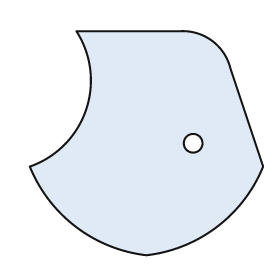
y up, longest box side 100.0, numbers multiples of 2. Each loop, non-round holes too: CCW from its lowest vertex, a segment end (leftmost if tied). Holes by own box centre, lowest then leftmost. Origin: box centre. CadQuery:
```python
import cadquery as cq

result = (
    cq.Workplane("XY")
    .moveTo(0.0, -48.0)
    .threePointArc((30.0, -36.0), (50.0, -10.0))
    .lineTo(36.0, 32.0)
    .threePointArc((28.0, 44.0), (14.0, 48.0))
    .lineTo(-30.0, 48.0)
    .threePointArc((-26.0, 14.0), (-50.0, -10.0))
    .threePointArc((-30.0, -36.0), (0.0, -48.0))
    .close()
    .moveTo(20.0, 0.0)
    .circle(4.0)
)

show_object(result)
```